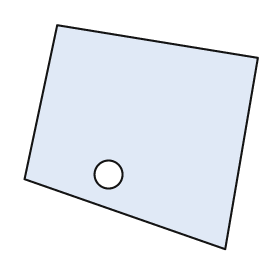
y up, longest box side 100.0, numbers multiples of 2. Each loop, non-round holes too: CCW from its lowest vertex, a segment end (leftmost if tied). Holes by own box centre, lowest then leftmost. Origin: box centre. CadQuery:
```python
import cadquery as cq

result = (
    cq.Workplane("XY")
    .moveTo(36.0, -48.0)
    .lineTo(50.0, 34.0)
    .lineTo(-36.0, 48.0)
    .lineTo(-50.0, -18.0)
    .close()
    .moveTo(-14.0, -16.0)
    .circle(6.0)
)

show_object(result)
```